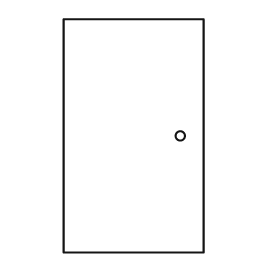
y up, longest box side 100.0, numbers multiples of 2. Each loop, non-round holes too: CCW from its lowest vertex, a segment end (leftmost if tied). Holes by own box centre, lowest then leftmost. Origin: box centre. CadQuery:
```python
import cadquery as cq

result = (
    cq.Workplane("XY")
    .moveTo(-30.0, -50.0)
    .lineTo(30.0, -50.0)
    .lineTo(30.0, 50.0)
    .lineTo(-30.0, 50.0)
    .close()
    .moveTo(20.0, 0.0)
    .circle(2.0)
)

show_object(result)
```